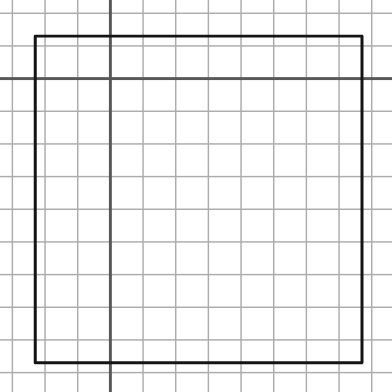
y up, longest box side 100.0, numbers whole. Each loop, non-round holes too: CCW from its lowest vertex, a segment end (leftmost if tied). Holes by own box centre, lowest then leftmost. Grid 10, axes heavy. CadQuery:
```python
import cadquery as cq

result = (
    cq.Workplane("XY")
    .moveTo(-23.0, -87.0)
    .lineTo(77.0, -87.0)
    .lineTo(77.0, 13.0)
    .lineTo(-23.0, 13.0)
    .close()
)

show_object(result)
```